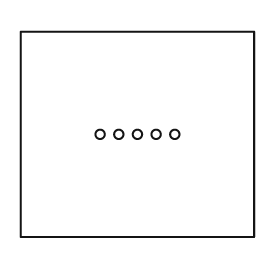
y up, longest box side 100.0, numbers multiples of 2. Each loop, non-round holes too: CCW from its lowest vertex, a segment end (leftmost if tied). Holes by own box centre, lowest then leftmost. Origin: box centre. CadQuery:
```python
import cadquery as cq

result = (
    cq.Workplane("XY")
    .moveTo(-50.0, -44.0)
    .lineTo(50.0, -44.0)
    .lineTo(50.0, 44.0)
    .lineTo(-50.0, 44.0)
    .close()
    .moveTo(-16.0, 0.0)
    .circle(2.0)
    .moveTo(-8.0, 0.0)
    .circle(2.0)
    .moveTo(0.0, 0.0)
    .circle(2.0)
    .moveTo(8.0, 0.0)
    .circle(2.0)
    .moveTo(16.0, 0.0)
    .circle(2.0)
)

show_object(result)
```